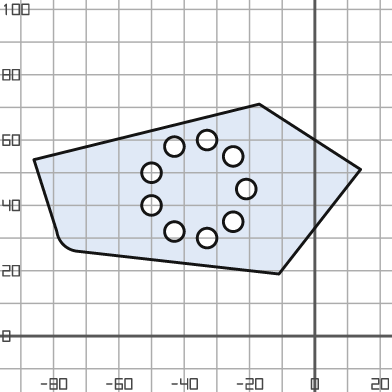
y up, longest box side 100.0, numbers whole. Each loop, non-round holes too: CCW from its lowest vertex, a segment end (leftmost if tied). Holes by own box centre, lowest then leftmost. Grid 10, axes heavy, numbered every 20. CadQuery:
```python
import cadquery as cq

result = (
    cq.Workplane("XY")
    .moveTo(-11.0, 19.0)
    .lineTo(14.0, 51.0)
    .lineTo(-17.0, 71.0)
    .lineTo(-86.0, 54.0)
    .lineTo(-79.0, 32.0)
    .threePointArc((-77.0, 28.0), (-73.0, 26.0))
    .close()
    .moveTo(-33.0, 30.0)
    .circle(3.0)
    .moveTo(-43.0, 32.0)
    .circle(3.0)
    .moveTo(-25.0, 35.0)
    .circle(3.0)
    .moveTo(-50.0, 40.0)
    .circle(3.0)
    .moveTo(-21.0, 45.0)
    .circle(3.0)
    .moveTo(-50.0, 50.0)
    .circle(3.0)
    .moveTo(-25.0, 55.0)
    .circle(3.0)
    .moveTo(-43.0, 58.0)
    .circle(3.0)
    .moveTo(-33.0, 60.0)
    .circle(3.0)
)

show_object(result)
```